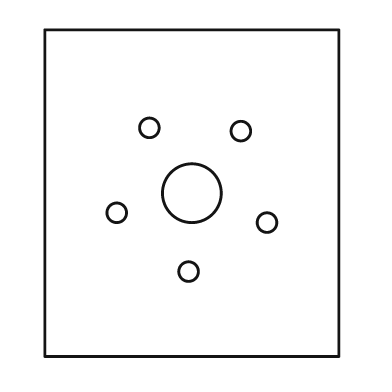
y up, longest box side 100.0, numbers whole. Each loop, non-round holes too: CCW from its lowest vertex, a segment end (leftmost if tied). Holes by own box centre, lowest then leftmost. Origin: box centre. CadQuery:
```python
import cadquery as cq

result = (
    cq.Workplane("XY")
    .moveTo(-45.0, -50.0)
    .lineTo(45.0, -50.0)
    .lineTo(45.0, 50.0)
    .lineTo(-45.0, 50.0)
    .close()
    .moveTo(-1.0, -24.0)
    .circle(3.0)
    .moveTo(23.0, -9.0)
    .circle(3.0)
    .moveTo(-23.0, -6.0)
    .circle(3.0)
    .moveTo(0.0, 0.0)
    .circle(9.0)
    .moveTo(15.0, 19.0)
    .circle(3.0)
    .moveTo(-13.0, 20.0)
    .circle(3.0)
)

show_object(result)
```